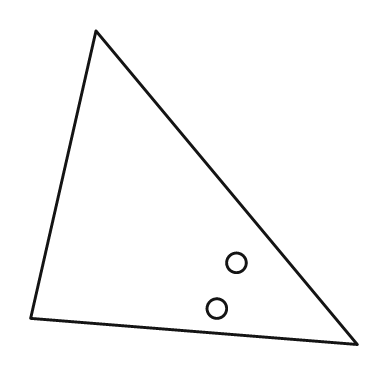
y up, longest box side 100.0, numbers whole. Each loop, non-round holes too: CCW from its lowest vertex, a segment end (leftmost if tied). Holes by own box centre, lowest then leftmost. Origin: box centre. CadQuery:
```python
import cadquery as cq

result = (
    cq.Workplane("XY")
    .moveTo(50.0, -48.0)
    .lineTo(-30.0, 48.0)
    .lineTo(-50.0, -40.0)
    .close()
    .moveTo(7.0, -37.0)
    .circle(3.0)
    .moveTo(13.0, -23.0)
    .circle(3.0)
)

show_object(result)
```